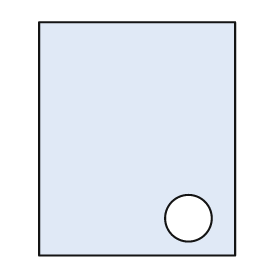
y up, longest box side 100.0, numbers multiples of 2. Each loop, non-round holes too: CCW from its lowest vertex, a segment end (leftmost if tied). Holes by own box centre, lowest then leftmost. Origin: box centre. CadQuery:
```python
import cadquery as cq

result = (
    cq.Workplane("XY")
    .moveTo(-42.0, -50.0)
    .lineTo(42.0, -50.0)
    .lineTo(42.0, 50.0)
    .lineTo(-42.0, 50.0)
    .close()
    .moveTo(22.0, -34.0)
    .circle(10.0)
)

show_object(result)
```